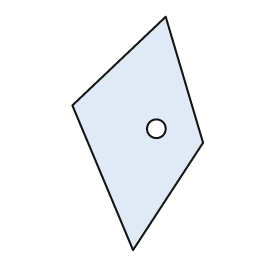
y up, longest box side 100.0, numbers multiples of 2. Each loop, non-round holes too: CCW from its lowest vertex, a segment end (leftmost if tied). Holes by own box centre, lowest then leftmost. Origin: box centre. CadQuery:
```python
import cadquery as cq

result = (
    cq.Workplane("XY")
    .moveTo(-2.0, -50.0)
    .lineTo(28.0, -4.0)
    .lineTo(12.0, 50.0)
    .lineTo(-28.0, 12.0)
    .close()
    .moveTo(8.0, 2.0)
    .circle(4.0)
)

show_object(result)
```